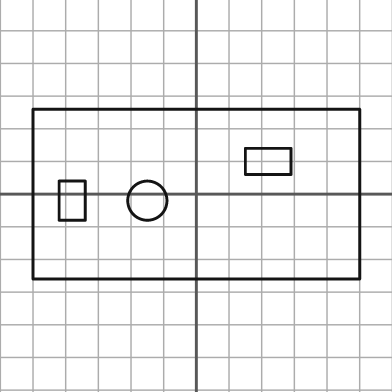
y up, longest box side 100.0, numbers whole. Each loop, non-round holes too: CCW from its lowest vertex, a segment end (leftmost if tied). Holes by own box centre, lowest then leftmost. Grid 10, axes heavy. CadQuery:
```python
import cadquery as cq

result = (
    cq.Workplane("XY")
    .moveTo(-50.0, -26.0)
    .lineTo(50.0, -26.0)
    .lineTo(50.0, 26.0)
    .lineTo(-50.0, 26.0)
    .close()
    .moveTo(-42.0, -8.0)
    .lineTo(-34.0, -8.0)
    .lineTo(-34.0, 4.0)
    .lineTo(-42.0, 4.0)
    .close()
    .moveTo(-15.0, -2.0)
    .circle(6.0)
    .moveTo(15.0, 6.0)
    .lineTo(29.0, 6.0)
    .lineTo(29.0, 14.0)
    .lineTo(15.0, 14.0)
    .close()
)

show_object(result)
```